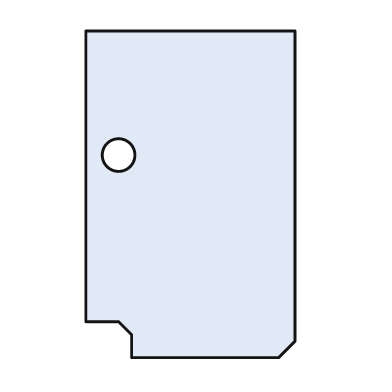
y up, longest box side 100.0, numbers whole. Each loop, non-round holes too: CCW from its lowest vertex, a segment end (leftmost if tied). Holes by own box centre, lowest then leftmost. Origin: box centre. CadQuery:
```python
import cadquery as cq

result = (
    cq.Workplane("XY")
    .moveTo(-18.0, -50.0)
    .lineTo(27.0, -50.0)
    .lineTo(32.0, -45.0)
    .lineTo(32.0, 50.0)
    .lineTo(-32.0, 50.0)
    .lineTo(-32.0, -39.0)
    .lineTo(-22.0, -39.0)
    .lineTo(-18.0, -43.0)
    .close()
    .moveTo(-22.0, 12.0)
    .circle(5.0)
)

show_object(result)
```